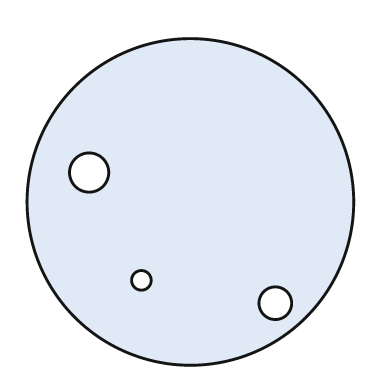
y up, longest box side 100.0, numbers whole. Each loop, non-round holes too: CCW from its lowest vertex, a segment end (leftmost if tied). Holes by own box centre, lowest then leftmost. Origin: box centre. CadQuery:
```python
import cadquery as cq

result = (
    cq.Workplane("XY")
    .moveTo(0.0, 0.0)
    .circle(50.0)
    .moveTo(26.0, -31.0)
    .circle(5.0)
    .moveTo(-15.0, -24.0)
    .circle(3.0)
    .moveTo(-31.0, 9.0)
    .circle(6.0)
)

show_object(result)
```